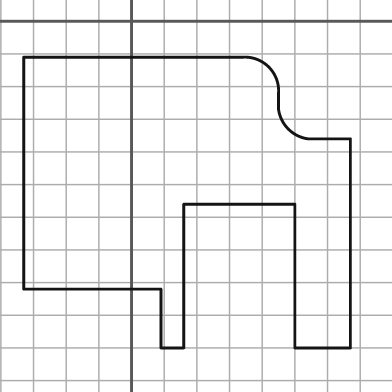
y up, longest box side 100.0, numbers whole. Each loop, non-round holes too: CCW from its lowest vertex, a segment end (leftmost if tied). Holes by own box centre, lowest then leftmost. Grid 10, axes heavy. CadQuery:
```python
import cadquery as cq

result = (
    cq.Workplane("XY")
    .moveTo(9.0, -100.0)
    .lineTo(16.0, -100.0)
    .lineTo(16.0, -56.0)
    .lineTo(50.0, -56.0)
    .lineTo(50.0, -100.0)
    .lineTo(67.0, -100.0)
    .lineTo(67.0, -36.0)
    .lineTo(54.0, -36.0)
    .threePointArc((48.0, -33.0), (45.0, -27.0))
    .lineTo(45.0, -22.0)
    .threePointArc((42.0, -14.0), (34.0, -11.0))
    .lineTo(-33.0, -11.0)
    .lineTo(-33.0, -82.0)
    .lineTo(9.0, -82.0)
    .close()
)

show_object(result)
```